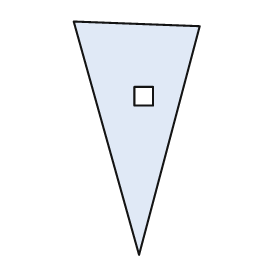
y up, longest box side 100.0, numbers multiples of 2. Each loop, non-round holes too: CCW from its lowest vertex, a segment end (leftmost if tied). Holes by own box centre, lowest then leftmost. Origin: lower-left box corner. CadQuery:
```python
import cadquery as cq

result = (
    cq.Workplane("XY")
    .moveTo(28.0, 0.0)
    .lineTo(54.0, 98.0)
    .lineTo(0.0, 100.0)
    .close()
    .moveTo(26.0, 64.0)
    .lineTo(34.0, 64.0)
    .lineTo(34.0, 72.0)
    .lineTo(26.0, 72.0)
    .close()
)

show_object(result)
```